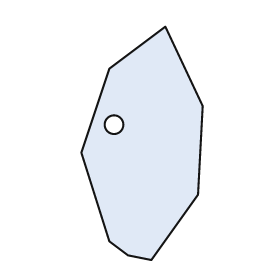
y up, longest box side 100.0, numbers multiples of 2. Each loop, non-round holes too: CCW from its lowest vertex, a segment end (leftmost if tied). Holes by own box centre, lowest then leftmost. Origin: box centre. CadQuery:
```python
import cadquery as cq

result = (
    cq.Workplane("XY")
    .moveTo(4.0, -50.0)
    .lineTo(24.0, -22.0)
    .lineTo(26.0, 16.0)
    .lineTo(10.0, 50.0)
    .lineTo(-14.0, 32.0)
    .lineTo(-26.0, -4.0)
    .lineTo(-14.0, -42.0)
    .lineTo(-6.0, -48.0)
    .close()
    .moveTo(-12.0, 8.0)
    .circle(4.0)
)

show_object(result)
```